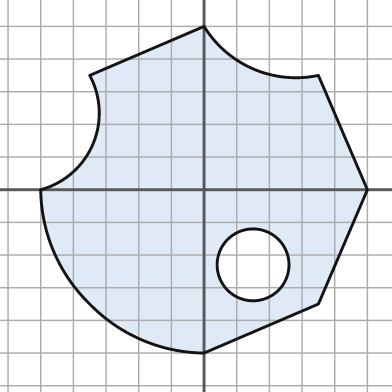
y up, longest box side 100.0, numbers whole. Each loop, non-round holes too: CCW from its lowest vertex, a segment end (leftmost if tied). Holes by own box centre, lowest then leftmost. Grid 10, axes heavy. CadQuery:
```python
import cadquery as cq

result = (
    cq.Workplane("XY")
    .moveTo(0.0, -50.0)
    .lineTo(35.0, -35.0)
    .lineTo(50.0, 0.0)
    .lineTo(35.0, 35.0)
    .threePointArc((15.0, 37.0), (0.0, 50.0))
    .lineTo(-35.0, 35.0)
    .threePointArc((-34.0, 14.0), (-50.0, 0.0))
    .threePointArc((-46.0, -19.0), (-35.0, -35.0))
    .threePointArc((-19.0, -46.0), (0.0, -50.0))
    .close()
    .moveTo(15.0, -23.0)
    .circle(11.0)
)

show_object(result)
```